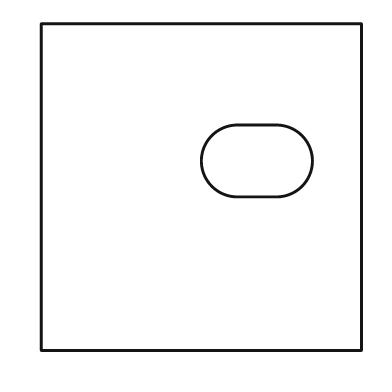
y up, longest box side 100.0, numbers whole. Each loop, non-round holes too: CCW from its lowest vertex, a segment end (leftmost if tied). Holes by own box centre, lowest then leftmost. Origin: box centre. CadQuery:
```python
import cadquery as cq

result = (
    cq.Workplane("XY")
    .moveTo(-49.0, -50.0)
    .lineTo(49.0, -50.0)
    .lineTo(49.0, 50.0)
    .lineTo(-49.0, 50.0)
    .close()
    .moveTo(11.0, -3.0)
    .lineTo(23.0, -3.0)
    .threePointArc((34.0, 8.0), (23.0, 19.0))
    .lineTo(11.0, 19.0)
    .threePointArc((0.0, 8.0), (11.0, -3.0))
    .close()
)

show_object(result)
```